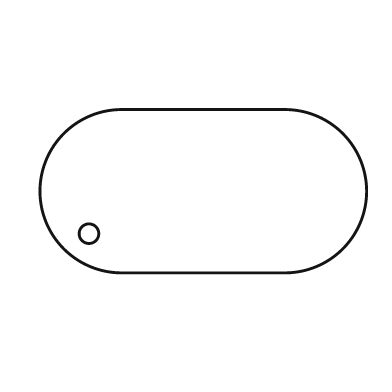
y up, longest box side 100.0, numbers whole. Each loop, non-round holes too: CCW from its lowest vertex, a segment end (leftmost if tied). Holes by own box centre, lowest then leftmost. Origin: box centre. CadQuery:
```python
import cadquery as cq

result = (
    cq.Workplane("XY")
    .moveTo(-25.0, -25.0)
    .lineTo(25.0, -25.0)
    .threePointArc((50.0, 0.0), (25.0, 25.0))
    .lineTo(-25.0, 25.0)
    .threePointArc((-50.0, 0.0), (-25.0, -25.0))
    .close()
    .moveTo(-35.0, -13.0)
    .circle(3.0)
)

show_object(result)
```